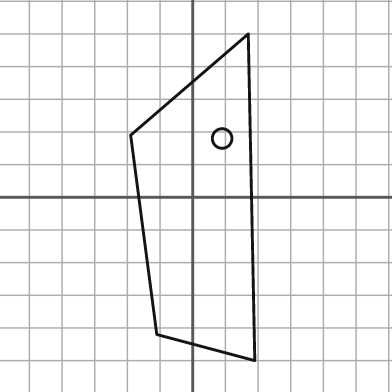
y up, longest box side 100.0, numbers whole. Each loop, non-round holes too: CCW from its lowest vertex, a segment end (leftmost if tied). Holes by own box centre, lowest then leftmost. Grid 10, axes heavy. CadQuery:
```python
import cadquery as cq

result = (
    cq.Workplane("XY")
    .moveTo(19.0, -50.0)
    .lineTo(17.0, 50.0)
    .lineTo(-19.0, 19.0)
    .lineTo(-11.0, -42.0)
    .close()
    .moveTo(9.0, 18.0)
    .circle(3.0)
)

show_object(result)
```